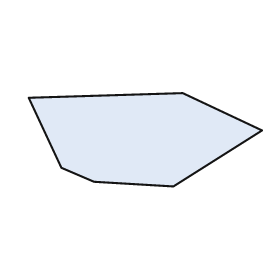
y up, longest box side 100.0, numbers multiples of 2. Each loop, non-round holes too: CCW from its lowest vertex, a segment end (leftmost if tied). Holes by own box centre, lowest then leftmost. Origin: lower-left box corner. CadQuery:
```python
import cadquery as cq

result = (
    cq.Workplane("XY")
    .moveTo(62.0, 0.0)
    .lineTo(100.0, 24.0)
    .lineTo(66.0, 40.0)
    .lineTo(0.0, 38.0)
    .lineTo(14.0, 8.0)
    .lineTo(28.0, 2.0)
    .close()
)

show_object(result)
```